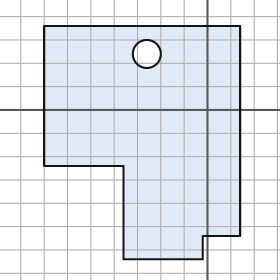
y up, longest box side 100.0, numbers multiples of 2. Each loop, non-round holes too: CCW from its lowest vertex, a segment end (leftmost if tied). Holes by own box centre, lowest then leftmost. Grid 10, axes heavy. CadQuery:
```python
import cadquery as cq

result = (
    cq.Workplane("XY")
    .moveTo(-36.0, -64.0)
    .lineTo(-2.0, -64.0)
    .lineTo(-2.0, -54.0)
    .lineTo(14.0, -54.0)
    .lineTo(14.0, 36.0)
    .lineTo(-70.0, 36.0)
    .lineTo(-70.0, -24.0)
    .lineTo(-36.0, -24.0)
    .close()
    .moveTo(-26.0, 24.0)
    .circle(6.0)
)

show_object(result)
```